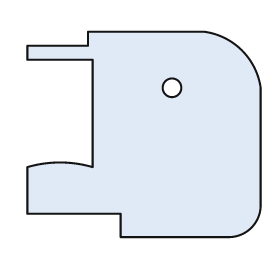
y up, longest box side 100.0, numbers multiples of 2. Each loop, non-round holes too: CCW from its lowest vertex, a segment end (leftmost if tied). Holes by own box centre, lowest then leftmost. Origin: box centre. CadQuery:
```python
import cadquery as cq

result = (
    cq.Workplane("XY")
    .moveTo(-10.0, -44.0)
    .lineTo(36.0, -44.0)
    .threePointArc((46.0, -40.0), (50.0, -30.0))
    .lineTo(50.0, 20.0)
    .threePointArc((42.0, 36.0), (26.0, 44.0))
    .lineTo(-24.0, 44.0)
    .lineTo(-24.0, 38.0)
    .lineTo(-50.0, 38.0)
    .lineTo(-50.0, 32.0)
    .lineTo(-22.0, 32.0)
    .lineTo(-22.0, -14.0)
    .threePointArc((-36.0, -12.0), (-50.0, -14.0))
    .lineTo(-50.0, -34.0)
    .lineTo(-10.0, -34.0)
    .close()
    .moveTo(12.0, 20.0)
    .circle(4.0)
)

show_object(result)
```